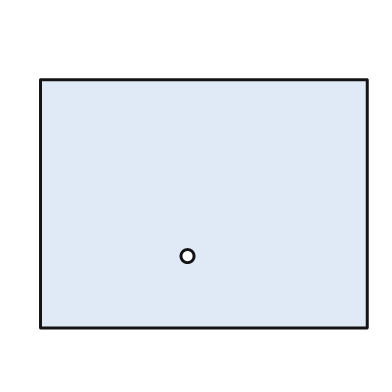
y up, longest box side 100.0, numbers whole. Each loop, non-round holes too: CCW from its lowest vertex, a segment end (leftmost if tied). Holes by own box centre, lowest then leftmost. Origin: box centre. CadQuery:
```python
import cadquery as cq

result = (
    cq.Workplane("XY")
    .moveTo(-50.0, -38.0)
    .lineTo(50.0, -38.0)
    .lineTo(50.0, 38.0)
    .lineTo(-50.0, 38.0)
    .close()
    .moveTo(-5.0, -16.0)
    .circle(2.0)
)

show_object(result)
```